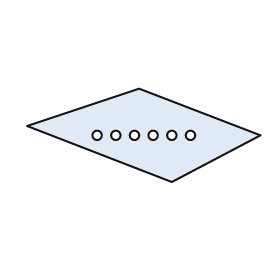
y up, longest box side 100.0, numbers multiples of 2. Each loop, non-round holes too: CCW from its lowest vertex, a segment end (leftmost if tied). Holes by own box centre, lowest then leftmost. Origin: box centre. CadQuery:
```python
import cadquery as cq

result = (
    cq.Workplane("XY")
    .moveTo(12.0, -20.0)
    .lineTo(50.0, 0.0)
    .lineTo(-2.0, 20.0)
    .lineTo(-50.0, 4.0)
    .close()
    .moveTo(-20.0, 0.0)
    .circle(2.0)
    .moveTo(-12.0, 0.0)
    .circle(2.0)
    .moveTo(-4.0, 0.0)
    .circle(2.0)
    .moveTo(4.0, 0.0)
    .circle(2.0)
    .moveTo(12.0, 0.0)
    .circle(2.0)
    .moveTo(20.0, 0.0)
    .circle(2.0)
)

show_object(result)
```